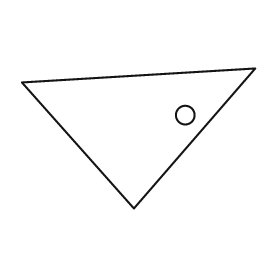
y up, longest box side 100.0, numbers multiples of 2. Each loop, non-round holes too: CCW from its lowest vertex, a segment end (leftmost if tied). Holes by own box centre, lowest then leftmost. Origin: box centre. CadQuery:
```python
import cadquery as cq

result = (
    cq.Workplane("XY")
    .moveTo(-2.0, -30.0)
    .lineTo(50.0, 30.0)
    .lineTo(-50.0, 24.0)
    .close()
    .moveTo(20.0, 10.0)
    .circle(4.0)
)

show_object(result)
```